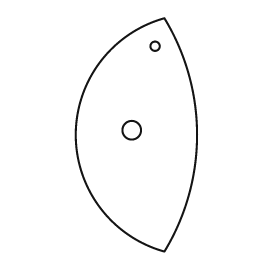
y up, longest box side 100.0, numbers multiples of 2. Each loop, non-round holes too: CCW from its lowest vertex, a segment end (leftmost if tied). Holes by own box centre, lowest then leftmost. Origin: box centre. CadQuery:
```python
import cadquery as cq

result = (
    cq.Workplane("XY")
    .moveTo(12.0, -50.0)
    .threePointArc((26.0, 0.0), (12.0, 50.0))
    .threePointArc((-26.0, 0.0), (12.0, -50.0))
    .close()
    .moveTo(-2.0, 2.0)
    .circle(4.0)
    .moveTo(8.0, 38.0)
    .circle(2.0)
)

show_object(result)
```